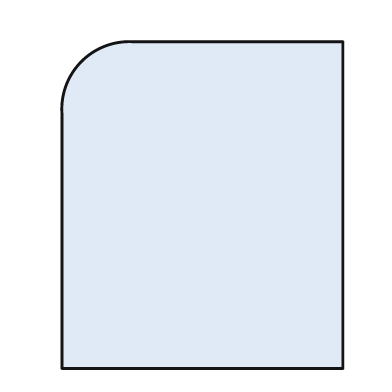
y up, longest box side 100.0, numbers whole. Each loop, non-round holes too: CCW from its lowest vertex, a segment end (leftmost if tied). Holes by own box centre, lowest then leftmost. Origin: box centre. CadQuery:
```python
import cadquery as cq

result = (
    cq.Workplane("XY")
    .moveTo(-43.0, -50.0)
    .lineTo(43.0, -50.0)
    .lineTo(43.0, 50.0)
    .lineTo(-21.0, 50.0)
    .threePointArc((-37.0, 44.0), (-43.0, 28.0))
    .close()
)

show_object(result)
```